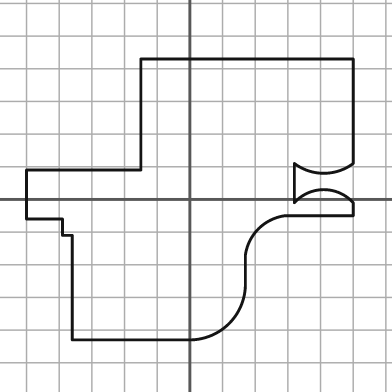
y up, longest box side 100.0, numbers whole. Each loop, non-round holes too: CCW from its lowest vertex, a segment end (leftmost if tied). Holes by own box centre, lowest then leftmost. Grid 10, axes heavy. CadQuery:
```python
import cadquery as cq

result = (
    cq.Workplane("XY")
    .moveTo(-36.0, -43.0)
    .lineTo(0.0, -43.0)
    .threePointArc((12.0, -38.0), (17.0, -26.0))
    .lineTo(17.0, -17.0)
    .threePointArc((21.0, -9.0), (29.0, -5.0))
    .lineTo(50.0, -5.0)
    .lineTo(50.0, -1.0)
    .threePointArc((41.0, 3.0), (32.0, -1.0))
    .lineTo(32.0, 11.0)
    .threePointArc((41.0, 8.0), (50.0, 11.0))
    .lineTo(50.0, 43.0)
    .lineTo(-15.0, 43.0)
    .lineTo(-15.0, 9.0)
    .lineTo(-50.0, 9.0)
    .lineTo(-50.0, -6.0)
    .lineTo(-39.0, -6.0)
    .lineTo(-39.0, -11.0)
    .lineTo(-36.0, -11.0)
    .close()
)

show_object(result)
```